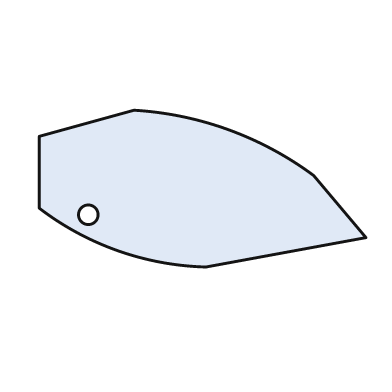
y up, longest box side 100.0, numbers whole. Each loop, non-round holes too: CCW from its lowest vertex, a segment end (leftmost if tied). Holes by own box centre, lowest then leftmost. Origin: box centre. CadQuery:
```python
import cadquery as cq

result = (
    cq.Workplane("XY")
    .moveTo(1.0, -24.0)
    .lineTo(50.0, -15.0)
    .lineTo(34.0, 4.0)
    .threePointArc((8.0, 18.0), (-21.0, 24.0))
    .lineTo(-50.0, 16.0)
    .lineTo(-50.0, -6.0)
    .threePointArc((-26.0, -19.0), (1.0, -24.0))
    .close()
    .moveTo(-35.0, -8.0)
    .circle(3.0)
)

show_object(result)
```